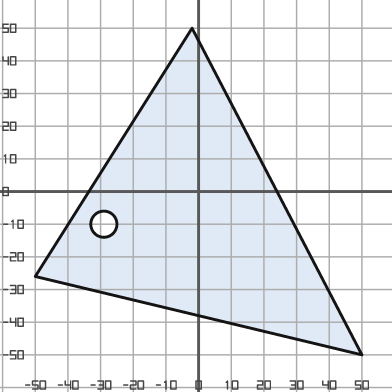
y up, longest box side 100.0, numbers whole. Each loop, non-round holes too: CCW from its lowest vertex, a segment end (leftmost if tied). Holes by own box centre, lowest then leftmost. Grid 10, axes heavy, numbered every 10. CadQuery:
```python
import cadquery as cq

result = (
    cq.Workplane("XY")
    .moveTo(50.0, -50.0)
    .lineTo(-2.0, 50.0)
    .lineTo(-50.0, -26.0)
    .close()
    .moveTo(-29.0, -10.0)
    .circle(4.0)
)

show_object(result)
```